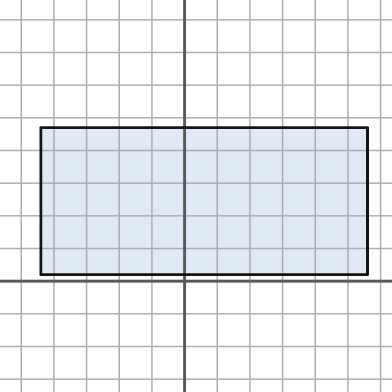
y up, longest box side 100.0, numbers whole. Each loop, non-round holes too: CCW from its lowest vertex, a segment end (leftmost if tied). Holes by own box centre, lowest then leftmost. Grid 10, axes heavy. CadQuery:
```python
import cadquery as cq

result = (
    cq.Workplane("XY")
    .moveTo(-44.0, 2.0)
    .lineTo(56.0, 2.0)
    .lineTo(56.0, 47.0)
    .lineTo(-44.0, 47.0)
    .close()
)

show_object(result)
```